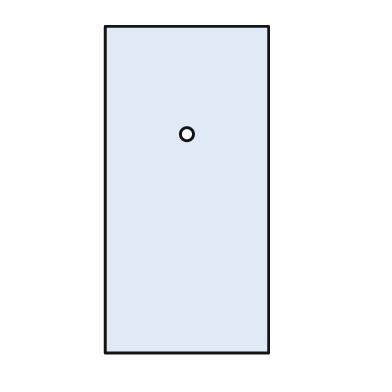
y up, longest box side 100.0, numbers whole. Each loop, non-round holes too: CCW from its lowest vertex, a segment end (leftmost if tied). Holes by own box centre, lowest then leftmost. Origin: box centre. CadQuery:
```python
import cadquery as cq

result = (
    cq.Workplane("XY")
    .moveTo(-25.0, -50.0)
    .lineTo(25.0, -50.0)
    .lineTo(25.0, 50.0)
    .lineTo(-25.0, 50.0)
    .close()
    .moveTo(0.0, 17.0)
    .circle(2.0)
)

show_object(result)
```